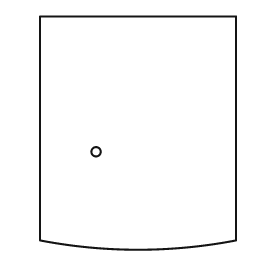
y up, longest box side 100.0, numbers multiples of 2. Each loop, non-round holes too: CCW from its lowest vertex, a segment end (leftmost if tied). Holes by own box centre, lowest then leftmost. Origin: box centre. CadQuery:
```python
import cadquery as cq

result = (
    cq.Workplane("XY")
    .moveTo(-42.0, -46.0)
    .threePointArc((0.0, -50.0), (42.0, -46.0))
    .lineTo(42.0, 50.0)
    .lineTo(-42.0, 50.0)
    .close()
    .moveTo(-18.0, -8.0)
    .circle(2.0)
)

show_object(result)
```